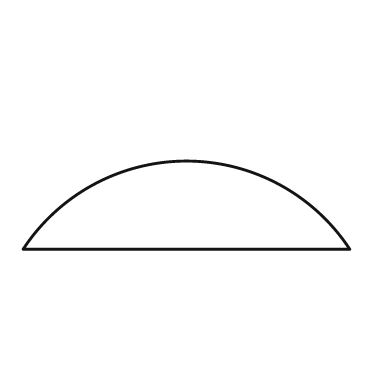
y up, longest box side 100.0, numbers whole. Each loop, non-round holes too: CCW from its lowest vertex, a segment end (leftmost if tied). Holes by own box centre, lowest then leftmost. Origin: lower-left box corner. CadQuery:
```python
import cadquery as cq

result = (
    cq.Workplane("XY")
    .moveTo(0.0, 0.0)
    .lineTo(100.0, 0.0)
    .threePointArc((50.0, 27.0), (0.0, 0.0))
    .close()
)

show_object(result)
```